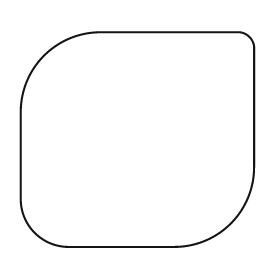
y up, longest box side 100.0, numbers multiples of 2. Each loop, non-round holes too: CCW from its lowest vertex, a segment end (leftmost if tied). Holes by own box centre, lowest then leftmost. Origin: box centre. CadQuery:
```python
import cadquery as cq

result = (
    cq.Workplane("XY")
    .moveTo(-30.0, -46.0)
    .lineTo(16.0, -46.0)
    .threePointArc((40.0, -36.0), (50.0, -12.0))
    .lineTo(50.0, 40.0)
    .threePointArc((48.0, 44.0), (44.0, 46.0))
    .lineTo(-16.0, 46.0)
    .threePointArc((-40.0, 36.0), (-50.0, 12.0))
    .lineTo(-50.0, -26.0)
    .threePointArc((-44.0, -40.0), (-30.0, -46.0))
    .close()
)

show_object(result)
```